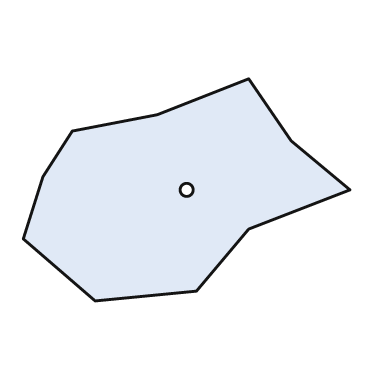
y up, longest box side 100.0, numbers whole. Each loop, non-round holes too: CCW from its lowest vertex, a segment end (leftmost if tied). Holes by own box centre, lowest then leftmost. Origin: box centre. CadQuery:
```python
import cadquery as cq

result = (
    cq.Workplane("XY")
    .moveTo(-28.0, -34.0)
    .lineTo(3.0, -31.0)
    .lineTo(19.0, -12.0)
    .lineTo(50.0, 0.0)
    .lineTo(32.0, 15.0)
    .lineTo(19.0, 34.0)
    .lineTo(-9.0, 23.0)
    .lineTo(-35.0, 18.0)
    .lineTo(-44.0, 4.0)
    .lineTo(-50.0, -15.0)
    .close()
    .moveTo(0.0, 0.0)
    .circle(2.0)
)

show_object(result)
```